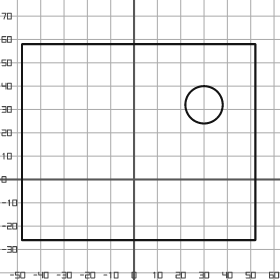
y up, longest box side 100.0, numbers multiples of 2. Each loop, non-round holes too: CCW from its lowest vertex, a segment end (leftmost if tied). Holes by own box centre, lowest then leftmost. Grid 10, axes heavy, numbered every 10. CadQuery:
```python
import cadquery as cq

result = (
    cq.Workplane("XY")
    .moveTo(-48.0, -26.0)
    .lineTo(52.0, -26.0)
    .lineTo(52.0, 58.0)
    .lineTo(-48.0, 58.0)
    .close()
    .moveTo(30.0, 32.0)
    .circle(8.0)
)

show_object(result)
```